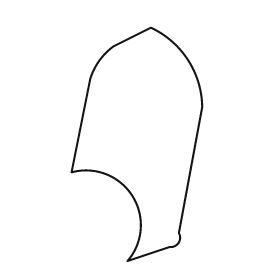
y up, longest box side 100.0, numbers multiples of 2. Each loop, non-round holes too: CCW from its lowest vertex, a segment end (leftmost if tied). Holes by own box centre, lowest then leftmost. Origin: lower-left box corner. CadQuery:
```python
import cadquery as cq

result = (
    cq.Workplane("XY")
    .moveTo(24.0, 0.0)
    .lineTo(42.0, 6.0)
    .threePointArc((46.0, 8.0), (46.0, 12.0))
    .lineTo(56.0, 66.0)
    .threePointArc((50.0, 86.0), (34.0, 100.0))
    .lineTo(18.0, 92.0)
    .threePointArc((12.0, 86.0), (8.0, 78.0))
    .lineTo(0.0, 38.0)
    .threePointArc((26.0, 28.0), (24.0, 0.0))
    .close()
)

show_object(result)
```